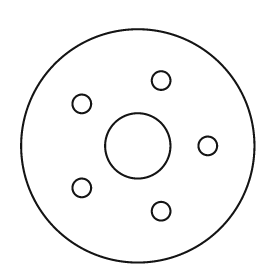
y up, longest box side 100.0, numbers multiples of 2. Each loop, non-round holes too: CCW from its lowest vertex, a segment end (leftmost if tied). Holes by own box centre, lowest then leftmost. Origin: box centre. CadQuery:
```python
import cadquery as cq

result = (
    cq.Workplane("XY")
    .moveTo(0.0, 0.0)
    .circle(50.0)
    .moveTo(10.0, -28.0)
    .circle(4.0)
    .moveTo(-24.0, -18.0)
    .circle(4.0)
    .moveTo(0.0, 0.0)
    .circle(14.0)
    .moveTo(30.0, 0.0)
    .circle(4.0)
    .moveTo(-24.0, 18.0)
    .circle(4.0)
    .moveTo(10.0, 28.0)
    .circle(4.0)
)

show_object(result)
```